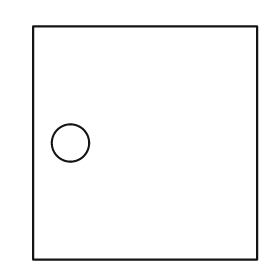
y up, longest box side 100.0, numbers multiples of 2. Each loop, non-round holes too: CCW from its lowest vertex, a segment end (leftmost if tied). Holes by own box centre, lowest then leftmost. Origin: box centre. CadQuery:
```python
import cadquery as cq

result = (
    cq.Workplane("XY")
    .moveTo(-48.0, -50.0)
    .lineTo(48.0, -50.0)
    .lineTo(48.0, 50.0)
    .lineTo(-48.0, 50.0)
    .close()
    .moveTo(-32.0, 0.0)
    .circle(8.0)
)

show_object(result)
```